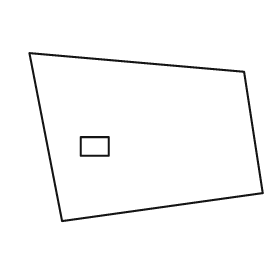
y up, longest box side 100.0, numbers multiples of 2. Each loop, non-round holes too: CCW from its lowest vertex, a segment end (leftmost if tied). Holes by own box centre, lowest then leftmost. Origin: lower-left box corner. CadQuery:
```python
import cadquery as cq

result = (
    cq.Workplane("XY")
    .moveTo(14.0, 0.0)
    .lineTo(100.0, 12.0)
    .lineTo(92.0, 64.0)
    .lineTo(0.0, 72.0)
    .close()
    .moveTo(22.0, 28.0)
    .lineTo(34.0, 28.0)
    .lineTo(34.0, 36.0)
    .lineTo(22.0, 36.0)
    .close()
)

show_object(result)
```